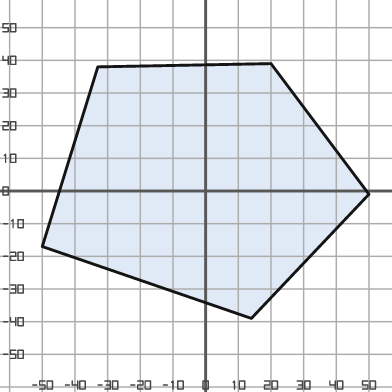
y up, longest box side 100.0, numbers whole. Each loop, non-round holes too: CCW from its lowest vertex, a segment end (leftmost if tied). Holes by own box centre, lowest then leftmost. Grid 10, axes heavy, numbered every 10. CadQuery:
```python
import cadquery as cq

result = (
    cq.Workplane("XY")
    .moveTo(14.0, -39.0)
    .lineTo(50.0, -1.0)
    .lineTo(20.0, 39.0)
    .lineTo(-33.0, 38.0)
    .lineTo(-50.0, -17.0)
    .close()
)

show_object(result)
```